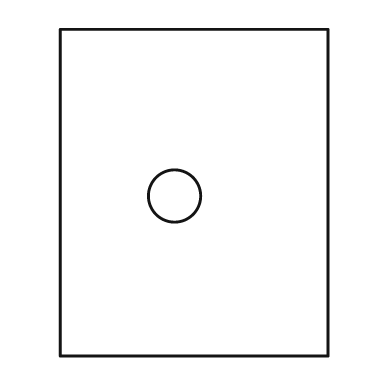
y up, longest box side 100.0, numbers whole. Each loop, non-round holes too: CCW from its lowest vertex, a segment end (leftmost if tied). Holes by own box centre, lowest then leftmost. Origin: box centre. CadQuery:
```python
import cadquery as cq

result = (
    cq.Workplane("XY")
    .moveTo(-41.0, -50.0)
    .lineTo(41.0, -50.0)
    .lineTo(41.0, 50.0)
    .lineTo(-41.0, 50.0)
    .close()
    .moveTo(-6.0, -1.0)
    .circle(8.0)
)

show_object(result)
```